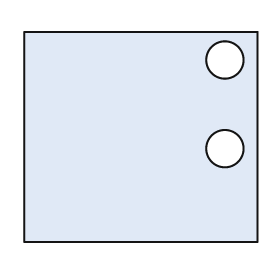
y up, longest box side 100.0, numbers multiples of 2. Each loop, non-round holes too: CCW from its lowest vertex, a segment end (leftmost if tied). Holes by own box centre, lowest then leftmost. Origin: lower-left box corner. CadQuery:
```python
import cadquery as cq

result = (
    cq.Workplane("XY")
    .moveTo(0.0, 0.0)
    .lineTo(100.0, 0.0)
    .lineTo(100.0, 90.0)
    .lineTo(0.0, 90.0)
    .close()
    .moveTo(86.0, 40.0)
    .circle(8.0)
    .moveTo(86.0, 78.0)
    .circle(8.0)
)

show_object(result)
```